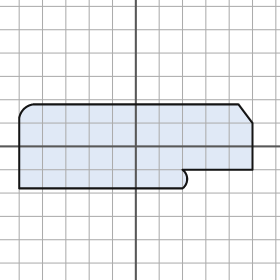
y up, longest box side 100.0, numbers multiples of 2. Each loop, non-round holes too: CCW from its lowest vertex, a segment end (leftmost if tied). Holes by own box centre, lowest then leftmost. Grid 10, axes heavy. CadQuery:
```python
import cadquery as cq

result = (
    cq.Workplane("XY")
    .moveTo(-50.0, -18.0)
    .lineTo(20.0, -18.0)
    .threePointArc((22.0, -14.0), (20.0, -10.0))
    .lineTo(50.0, -10.0)
    .lineTo(50.0, 10.0)
    .lineTo(44.0, 18.0)
    .lineTo(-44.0, 18.0)
    .threePointArc((-48.0, 16.0), (-50.0, 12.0))
    .close()
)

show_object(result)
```